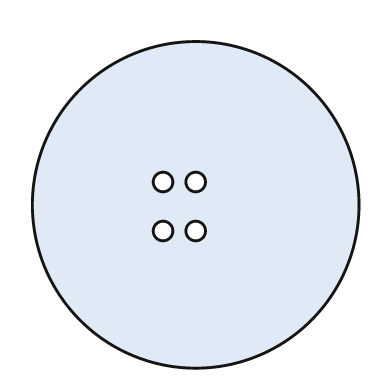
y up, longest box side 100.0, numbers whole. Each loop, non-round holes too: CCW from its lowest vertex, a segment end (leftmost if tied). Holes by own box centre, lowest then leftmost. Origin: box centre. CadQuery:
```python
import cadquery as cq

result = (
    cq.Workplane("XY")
    .moveTo(0.0, 0.0)
    .circle(50.0)
    .moveTo(-10.0, -8.0)
    .circle(3.0)
    .moveTo(0.0, -8.0)
    .circle(3.0)
    .moveTo(-10.0, 7.0)
    .circle(3.0)
    .moveTo(0.0, 7.0)
    .circle(3.0)
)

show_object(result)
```